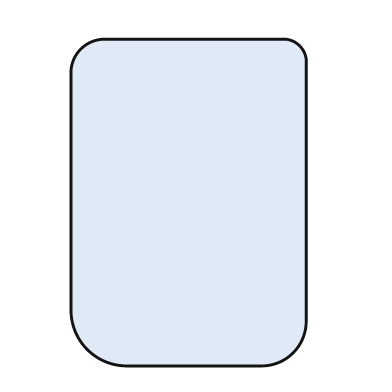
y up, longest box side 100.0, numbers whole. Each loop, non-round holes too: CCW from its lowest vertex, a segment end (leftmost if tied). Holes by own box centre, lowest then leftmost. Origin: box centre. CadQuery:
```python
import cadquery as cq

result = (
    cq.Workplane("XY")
    .moveTo(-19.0, -50.0)
    .lineTo(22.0, -50.0)
    .threePointArc((32.0, -46.0), (36.0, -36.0))
    .lineTo(36.0, 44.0)
    .threePointArc((34.0, 48.0), (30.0, 50.0))
    .lineTo(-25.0, 50.0)
    .threePointArc((-33.0, 47.0), (-36.0, 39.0))
    .lineTo(-36.0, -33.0)
    .threePointArc((-31.0, -45.0), (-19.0, -50.0))
    .close()
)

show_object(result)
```